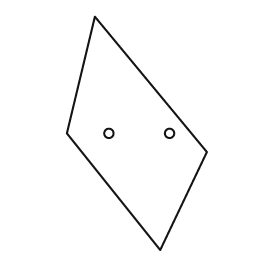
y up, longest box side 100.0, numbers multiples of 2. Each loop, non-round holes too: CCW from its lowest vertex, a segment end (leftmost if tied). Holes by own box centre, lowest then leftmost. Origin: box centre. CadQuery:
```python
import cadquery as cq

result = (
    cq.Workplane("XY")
    .moveTo(10.0, -50.0)
    .lineTo(30.0, -8.0)
    .lineTo(-18.0, 50.0)
    .lineTo(-30.0, 0.0)
    .close()
    .moveTo(-12.0, 0.0)
    .circle(2.0)
    .moveTo(14.0, 0.0)
    .circle(2.0)
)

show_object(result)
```